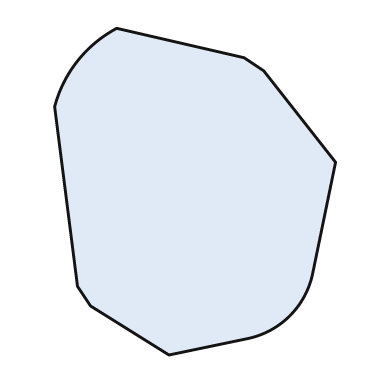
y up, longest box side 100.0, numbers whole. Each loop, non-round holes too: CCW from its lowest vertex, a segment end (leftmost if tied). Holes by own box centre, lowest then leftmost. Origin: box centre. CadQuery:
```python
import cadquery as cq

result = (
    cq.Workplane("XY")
    .moveTo(-8.0, -50.0)
    .lineTo(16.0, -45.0)
    .threePointArc((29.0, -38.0), (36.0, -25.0))
    .lineTo(43.0, 9.0)
    .lineTo(21.0, 37.0)
    .lineTo(15.0, 41.0)
    .lineTo(-24.0, 50.0)
    .threePointArc((-36.0, 40.0), (-43.0, 26.0))
    .lineTo(-36.0, -29.0)
    .lineTo(-32.0, -35.0)
    .close()
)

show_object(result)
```